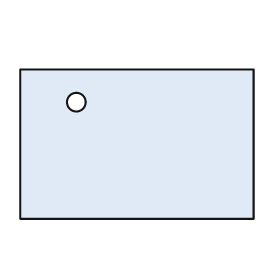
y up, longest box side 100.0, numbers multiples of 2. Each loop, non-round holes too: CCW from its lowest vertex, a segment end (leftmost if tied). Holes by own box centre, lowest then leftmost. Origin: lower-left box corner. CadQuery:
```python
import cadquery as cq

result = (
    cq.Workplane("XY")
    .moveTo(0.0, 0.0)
    .lineTo(100.0, 0.0)
    .lineTo(100.0, 64.0)
    .lineTo(0.0, 64.0)
    .close()
    .moveTo(24.0, 50.0)
    .circle(4.0)
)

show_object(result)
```